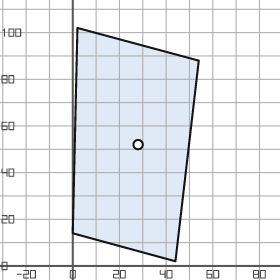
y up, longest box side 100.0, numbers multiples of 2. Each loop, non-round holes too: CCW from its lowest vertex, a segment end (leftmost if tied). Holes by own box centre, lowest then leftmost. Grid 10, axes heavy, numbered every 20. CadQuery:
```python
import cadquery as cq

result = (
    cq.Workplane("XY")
    .moveTo(44.0, 2.0)
    .lineTo(54.0, 88.0)
    .lineTo(2.0, 102.0)
    .lineTo(0.0, 14.0)
    .close()
    .moveTo(28.0, 52.0)
    .circle(2.0)
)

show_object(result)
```